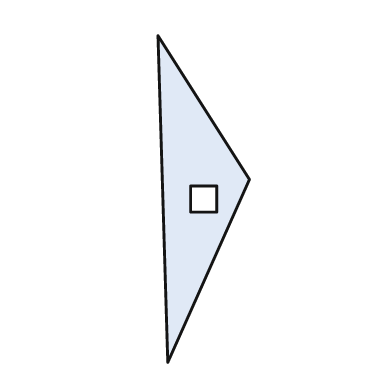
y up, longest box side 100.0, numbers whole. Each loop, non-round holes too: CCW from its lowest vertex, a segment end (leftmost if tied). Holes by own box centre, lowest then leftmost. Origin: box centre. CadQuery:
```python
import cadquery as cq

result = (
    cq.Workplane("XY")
    .moveTo(-11.0, -50.0)
    .lineTo(14.0, 6.0)
    .lineTo(-14.0, 50.0)
    .close()
    .moveTo(-4.0, -4.0)
    .lineTo(4.0, -4.0)
    .lineTo(4.0, 4.0)
    .lineTo(-4.0, 4.0)
    .close()
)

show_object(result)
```